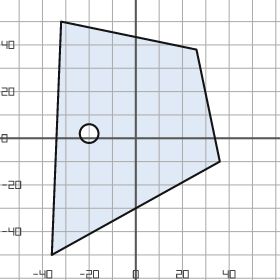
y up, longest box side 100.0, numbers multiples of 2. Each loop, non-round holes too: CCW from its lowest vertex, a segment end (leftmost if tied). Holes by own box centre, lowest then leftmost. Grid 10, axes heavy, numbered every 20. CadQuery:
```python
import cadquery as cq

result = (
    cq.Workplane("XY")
    .moveTo(-36.0, -50.0)
    .lineTo(36.0, -10.0)
    .lineTo(26.0, 38.0)
    .lineTo(-32.0, 50.0)
    .close()
    .moveTo(-20.0, 2.0)
    .circle(4.0)
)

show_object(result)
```